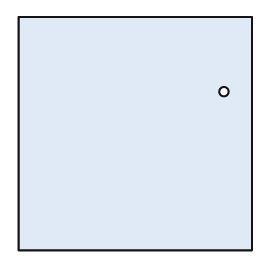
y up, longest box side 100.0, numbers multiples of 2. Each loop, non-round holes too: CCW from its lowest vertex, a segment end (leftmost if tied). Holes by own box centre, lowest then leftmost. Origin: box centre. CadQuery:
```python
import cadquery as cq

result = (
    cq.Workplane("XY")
    .moveTo(-50.0, -50.0)
    .lineTo(50.0, -50.0)
    .lineTo(50.0, 50.0)
    .lineTo(-50.0, 50.0)
    .close()
    .moveTo(38.0, 18.0)
    .circle(2.0)
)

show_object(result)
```